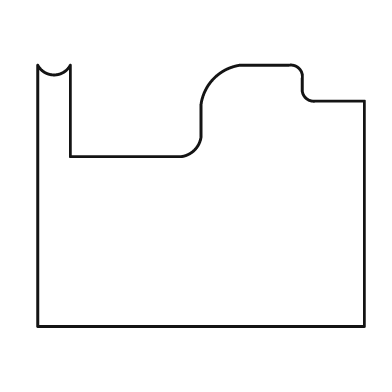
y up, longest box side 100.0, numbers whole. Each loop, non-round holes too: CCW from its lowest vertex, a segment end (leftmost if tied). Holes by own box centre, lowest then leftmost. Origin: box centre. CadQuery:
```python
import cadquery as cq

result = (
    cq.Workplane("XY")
    .moveTo(-50.0, -40.0)
    .lineTo(50.0, -40.0)
    .lineTo(50.0, 29.0)
    .lineTo(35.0, 29.0)
    .threePointArc((32.0, 30.0), (31.0, 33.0))
    .lineTo(31.0, 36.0)
    .threePointArc((30.0, 39.0), (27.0, 40.0))
    .lineTo(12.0, 40.0)
    .threePointArc((4.0, 36.0), (0.0, 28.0))
    .lineTo(0.0, 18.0)
    .threePointArc((-2.0, 14.0), (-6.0, 12.0))
    .lineTo(-40.0, 12.0)
    .lineTo(-40.0, 40.0)
    .threePointArc((-45.0, 37.0), (-50.0, 40.0))
    .close()
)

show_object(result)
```